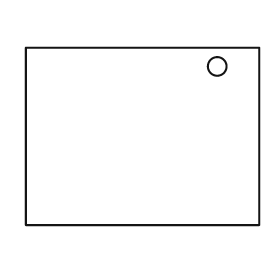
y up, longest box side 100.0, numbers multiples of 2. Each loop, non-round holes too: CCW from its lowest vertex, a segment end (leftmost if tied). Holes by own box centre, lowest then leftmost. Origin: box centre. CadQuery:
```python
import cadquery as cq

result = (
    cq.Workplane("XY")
    .moveTo(-50.0, -38.0)
    .lineTo(50.0, -38.0)
    .lineTo(50.0, 38.0)
    .lineTo(-50.0, 38.0)
    .close()
    .moveTo(32.0, 30.0)
    .circle(4.0)
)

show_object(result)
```